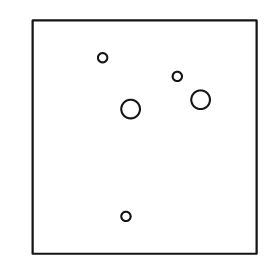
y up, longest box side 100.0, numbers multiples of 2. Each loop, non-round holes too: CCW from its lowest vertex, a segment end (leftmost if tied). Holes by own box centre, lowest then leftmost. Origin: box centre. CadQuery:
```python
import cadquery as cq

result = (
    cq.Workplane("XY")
    .moveTo(-48.0, -50.0)
    .lineTo(48.0, -50.0)
    .lineTo(48.0, 50.0)
    .lineTo(-48.0, 50.0)
    .close()
    .moveTo(-8.0, -34.0)
    .circle(2.0)
    .moveTo(-6.0, 12.0)
    .circle(4.0)
    .moveTo(24.0, 16.0)
    .circle(4.0)
    .moveTo(14.0, 26.0)
    .circle(2.0)
    .moveTo(-18.0, 34.0)
    .circle(2.0)
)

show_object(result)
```